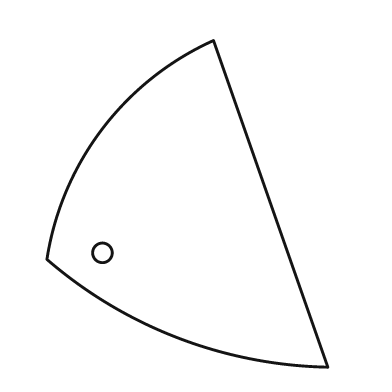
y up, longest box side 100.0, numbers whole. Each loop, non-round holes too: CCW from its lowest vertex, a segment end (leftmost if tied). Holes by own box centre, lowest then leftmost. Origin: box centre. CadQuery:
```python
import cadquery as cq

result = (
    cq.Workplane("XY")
    .moveTo(43.0, -50.0)
    .lineTo(8.0, 50.0)
    .threePointArc((-26.0, 23.0), (-43.0, -17.0))
    .threePointArc((-3.0, -41.0), (43.0, -50.0))
    .close()
    .moveTo(-26.0, -15.0)
    .circle(3.0)
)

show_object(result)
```